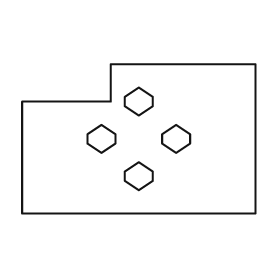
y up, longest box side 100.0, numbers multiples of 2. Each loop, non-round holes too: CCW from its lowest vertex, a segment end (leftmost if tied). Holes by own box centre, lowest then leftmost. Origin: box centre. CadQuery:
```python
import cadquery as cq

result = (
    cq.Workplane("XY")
    .moveTo(-50.0, -32.0)
    .lineTo(50.0, -32.0)
    .lineTo(50.0, 32.0)
    .lineTo(-12.0, 32.0)
    .lineTo(-12.0, 16.0)
    .lineTo(-50.0, 16.0)
    .close()
    .moveTo(0.0, -22.0)
    .lineTo(6.0, -18.0)
    .lineTo(6.0, -14.0)
    .lineTo(0.0, -10.0)
    .lineTo(-6.0, -14.0)
    .lineTo(-6.0, -18.0)
    .close()
    .moveTo(-16.0, -6.0)
    .lineTo(-10.0, -2.0)
    .lineTo(-10.0, 2.0)
    .lineTo(-16.0, 6.0)
    .lineTo(-22.0, 2.0)
    .lineTo(-22.0, -2.0)
    .close()
    .moveTo(16.0, -6.0)
    .lineTo(22.0, -2.0)
    .lineTo(22.0, 2.0)
    .lineTo(16.0, 6.0)
    .lineTo(10.0, 2.0)
    .lineTo(10.0, -2.0)
    .close()
    .moveTo(0.0, 10.0)
    .lineTo(6.0, 14.0)
    .lineTo(6.0, 18.0)
    .lineTo(0.0, 22.0)
    .lineTo(-6.0, 18.0)
    .lineTo(-6.0, 14.0)
    .close()
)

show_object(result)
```